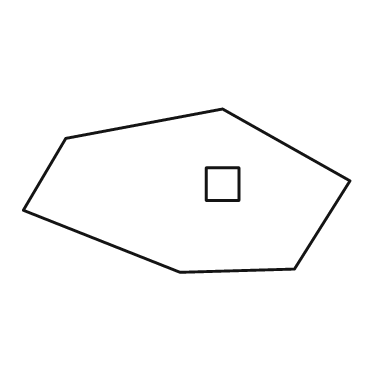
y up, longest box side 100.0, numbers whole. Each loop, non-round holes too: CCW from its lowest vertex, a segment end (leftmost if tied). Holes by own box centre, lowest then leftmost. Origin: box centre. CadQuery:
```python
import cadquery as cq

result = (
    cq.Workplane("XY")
    .moveTo(-2.0, -25.0)
    .lineTo(33.0, -24.0)
    .lineTo(50.0, 3.0)
    .lineTo(11.0, 25.0)
    .lineTo(-37.0, 16.0)
    .lineTo(-50.0, -6.0)
    .close()
    .moveTo(6.0, -3.0)
    .lineTo(16.0, -3.0)
    .lineTo(16.0, 7.0)
    .lineTo(6.0, 7.0)
    .close()
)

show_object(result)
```